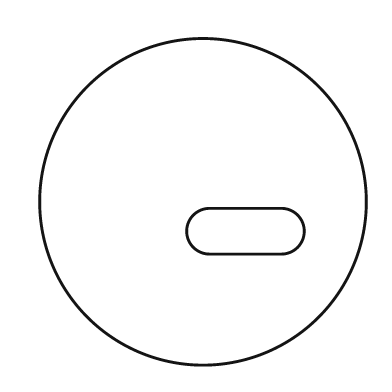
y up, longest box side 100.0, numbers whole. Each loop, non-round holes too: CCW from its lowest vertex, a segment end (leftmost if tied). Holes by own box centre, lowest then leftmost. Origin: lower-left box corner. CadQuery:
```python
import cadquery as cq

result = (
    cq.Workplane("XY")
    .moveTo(50.0, 50.0)
    .circle(50.0)
    .moveTo(52.0, 34.0)
    .lineTo(74.0, 34.0)
    .threePointArc((81.0, 41.0), (74.0, 48.0))
    .lineTo(52.0, 48.0)
    .threePointArc((45.0, 41.0), (52.0, 34.0))
    .close()
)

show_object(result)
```